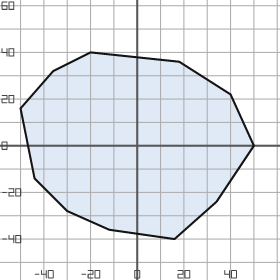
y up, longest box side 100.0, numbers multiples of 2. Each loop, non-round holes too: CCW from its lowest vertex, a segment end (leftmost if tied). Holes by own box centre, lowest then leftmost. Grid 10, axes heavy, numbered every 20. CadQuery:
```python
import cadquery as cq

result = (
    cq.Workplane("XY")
    .moveTo(16.0, -40.0)
    .lineTo(34.0, -24.0)
    .lineTo(50.0, 0.0)
    .lineTo(40.0, 22.0)
    .lineTo(18.0, 36.0)
    .lineTo(-20.0, 40.0)
    .lineTo(-36.0, 32.0)
    .lineTo(-50.0, 16.0)
    .lineTo(-44.0, -14.0)
    .lineTo(-30.0, -28.0)
    .lineTo(-12.0, -36.0)
    .close()
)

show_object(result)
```